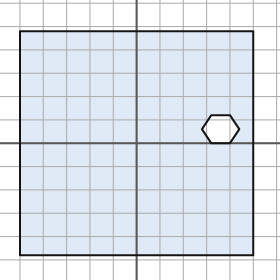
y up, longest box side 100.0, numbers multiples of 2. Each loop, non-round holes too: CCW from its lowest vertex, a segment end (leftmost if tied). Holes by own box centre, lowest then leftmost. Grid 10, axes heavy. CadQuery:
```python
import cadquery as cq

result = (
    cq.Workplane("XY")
    .moveTo(-50.0, -48.0)
    .lineTo(50.0, -48.0)
    .lineTo(50.0, 48.0)
    .lineTo(-50.0, 48.0)
    .close()
    .moveTo(32.0, 0.0)
    .lineTo(40.0, 0.0)
    .lineTo(44.0, 6.0)
    .lineTo(40.0, 12.0)
    .lineTo(32.0, 12.0)
    .lineTo(28.0, 6.0)
    .close()
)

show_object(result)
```